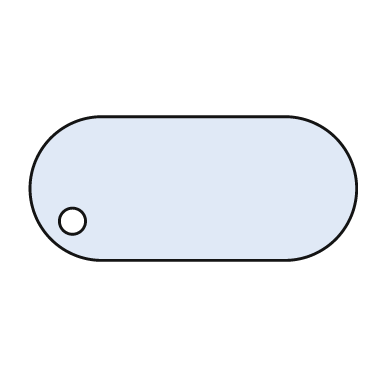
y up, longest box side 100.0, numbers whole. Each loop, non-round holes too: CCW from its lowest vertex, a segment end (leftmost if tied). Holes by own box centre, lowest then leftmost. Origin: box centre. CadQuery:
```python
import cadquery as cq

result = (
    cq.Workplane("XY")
    .moveTo(-28.0, -22.0)
    .lineTo(28.0, -22.0)
    .threePointArc((50.0, 0.0), (28.0, 22.0))
    .lineTo(-28.0, 22.0)
    .threePointArc((-50.0, 0.0), (-28.0, -22.0))
    .close()
    .moveTo(-37.0, -10.0)
    .circle(4.0)
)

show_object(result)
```